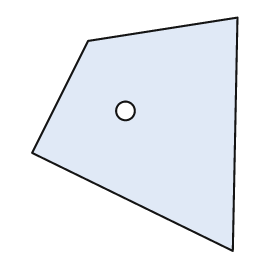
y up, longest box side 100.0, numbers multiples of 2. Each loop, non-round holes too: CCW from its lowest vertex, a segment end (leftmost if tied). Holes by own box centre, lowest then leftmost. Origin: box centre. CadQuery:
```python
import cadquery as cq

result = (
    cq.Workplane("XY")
    .moveTo(42.0, -50.0)
    .lineTo(44.0, 50.0)
    .lineTo(-20.0, 40.0)
    .lineTo(-44.0, -8.0)
    .close()
    .moveTo(-4.0, 10.0)
    .circle(4.0)
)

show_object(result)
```